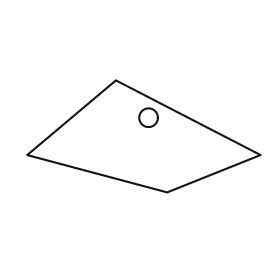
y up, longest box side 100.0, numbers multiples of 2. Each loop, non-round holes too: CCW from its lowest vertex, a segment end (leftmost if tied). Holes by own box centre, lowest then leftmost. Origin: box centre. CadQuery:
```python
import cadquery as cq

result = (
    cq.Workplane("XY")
    .moveTo(10.0, -24.0)
    .lineTo(50.0, -8.0)
    .lineTo(-12.0, 24.0)
    .lineTo(-50.0, -8.0)
    .close()
    .moveTo(2.0, 8.0)
    .circle(4.0)
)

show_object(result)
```